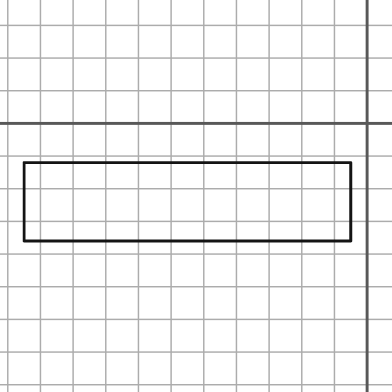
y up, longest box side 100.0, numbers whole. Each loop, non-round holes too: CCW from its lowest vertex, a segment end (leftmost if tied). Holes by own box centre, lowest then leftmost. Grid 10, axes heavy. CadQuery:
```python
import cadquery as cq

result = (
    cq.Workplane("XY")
    .moveTo(-105.0, -36.0)
    .lineTo(-5.0, -36.0)
    .lineTo(-5.0, -12.0)
    .lineTo(-105.0, -12.0)
    .close()
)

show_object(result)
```